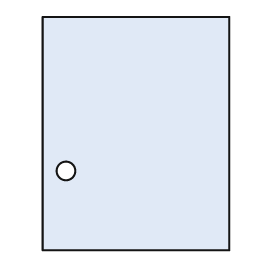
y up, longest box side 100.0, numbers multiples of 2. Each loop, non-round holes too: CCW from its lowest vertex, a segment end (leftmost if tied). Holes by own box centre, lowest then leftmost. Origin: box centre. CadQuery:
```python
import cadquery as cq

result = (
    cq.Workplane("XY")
    .moveTo(-40.0, -50.0)
    .lineTo(40.0, -50.0)
    .lineTo(40.0, 50.0)
    .lineTo(-40.0, 50.0)
    .close()
    .moveTo(-30.0, -16.0)
    .circle(4.0)
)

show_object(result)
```